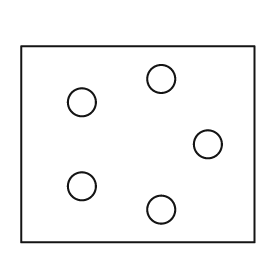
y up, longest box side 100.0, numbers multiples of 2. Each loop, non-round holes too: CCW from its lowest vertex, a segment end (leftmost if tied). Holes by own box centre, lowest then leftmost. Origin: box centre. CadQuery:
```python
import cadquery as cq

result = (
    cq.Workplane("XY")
    .moveTo(-50.0, -42.0)
    .lineTo(50.0, -42.0)
    .lineTo(50.0, 42.0)
    .lineTo(-50.0, 42.0)
    .close()
    .moveTo(10.0, -28.0)
    .circle(6.0)
    .moveTo(-24.0, -18.0)
    .circle(6.0)
    .moveTo(30.0, 0.0)
    .circle(6.0)
    .moveTo(-24.0, 18.0)
    .circle(6.0)
    .moveTo(10.0, 28.0)
    .circle(6.0)
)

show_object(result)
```